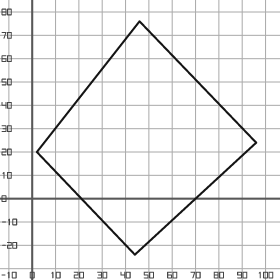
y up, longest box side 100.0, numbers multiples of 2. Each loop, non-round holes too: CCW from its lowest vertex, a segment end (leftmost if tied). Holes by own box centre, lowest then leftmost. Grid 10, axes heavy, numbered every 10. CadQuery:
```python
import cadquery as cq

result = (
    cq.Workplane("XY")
    .moveTo(44.0, -24.0)
    .lineTo(96.0, 24.0)
    .lineTo(46.0, 76.0)
    .lineTo(2.0, 20.0)
    .close()
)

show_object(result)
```